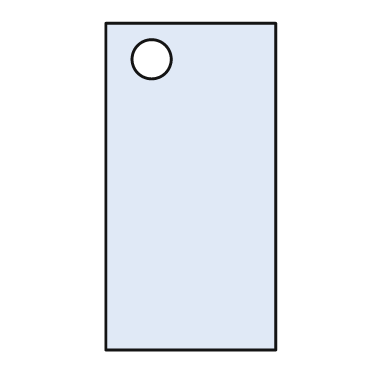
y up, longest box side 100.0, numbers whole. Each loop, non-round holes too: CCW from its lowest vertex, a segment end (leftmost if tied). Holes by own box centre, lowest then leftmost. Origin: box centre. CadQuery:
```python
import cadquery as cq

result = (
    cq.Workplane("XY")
    .moveTo(-26.0, -50.0)
    .lineTo(26.0, -50.0)
    .lineTo(26.0, 50.0)
    .lineTo(-26.0, 50.0)
    .close()
    .moveTo(-12.0, 39.0)
    .circle(6.0)
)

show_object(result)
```